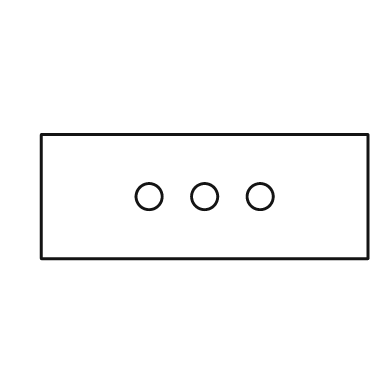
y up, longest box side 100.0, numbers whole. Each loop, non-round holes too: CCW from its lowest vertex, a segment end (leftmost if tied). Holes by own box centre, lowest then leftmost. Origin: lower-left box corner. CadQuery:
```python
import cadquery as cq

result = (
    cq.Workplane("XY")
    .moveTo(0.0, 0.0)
    .lineTo(100.0, 0.0)
    .lineTo(100.0, 38.0)
    .lineTo(0.0, 38.0)
    .close()
    .moveTo(33.0, 19.0)
    .circle(4.0)
    .moveTo(50.0, 19.0)
    .circle(4.0)
    .moveTo(67.0, 19.0)
    .circle(4.0)
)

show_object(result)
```